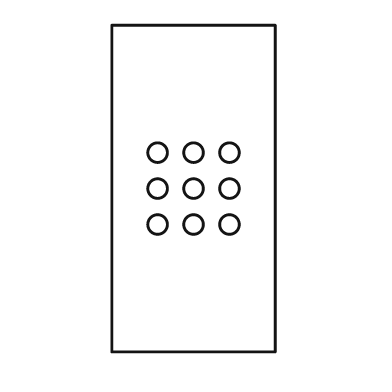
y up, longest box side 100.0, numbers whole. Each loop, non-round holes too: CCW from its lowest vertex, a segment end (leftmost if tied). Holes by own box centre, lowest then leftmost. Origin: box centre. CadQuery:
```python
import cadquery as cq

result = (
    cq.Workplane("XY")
    .moveTo(-25.0, -50.0)
    .lineTo(25.0, -50.0)
    .lineTo(25.0, 50.0)
    .lineTo(-25.0, 50.0)
    .close()
    .moveTo(-11.0, -11.0)
    .circle(3.0)
    .moveTo(0.0, -11.0)
    .circle(3.0)
    .moveTo(11.0, -11.0)
    .circle(3.0)
    .moveTo(-11.0, 0.0)
    .circle(3.0)
    .moveTo(0.0, 0.0)
    .circle(3.0)
    .moveTo(11.0, 0.0)
    .circle(3.0)
    .moveTo(-11.0, 11.0)
    .circle(3.0)
    .moveTo(0.0, 11.0)
    .circle(3.0)
    .moveTo(11.0, 11.0)
    .circle(3.0)
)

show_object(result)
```